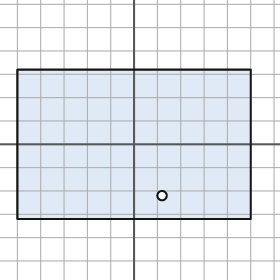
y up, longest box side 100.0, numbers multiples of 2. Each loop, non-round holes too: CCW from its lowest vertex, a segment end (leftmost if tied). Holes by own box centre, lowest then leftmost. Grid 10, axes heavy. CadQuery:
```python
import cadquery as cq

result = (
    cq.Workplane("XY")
    .moveTo(-50.0, -32.0)
    .lineTo(50.0, -32.0)
    .lineTo(50.0, 32.0)
    .lineTo(-50.0, 32.0)
    .close()
    .moveTo(12.0, -22.0)
    .circle(2.0)
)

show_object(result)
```